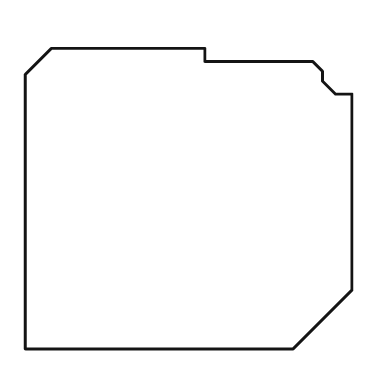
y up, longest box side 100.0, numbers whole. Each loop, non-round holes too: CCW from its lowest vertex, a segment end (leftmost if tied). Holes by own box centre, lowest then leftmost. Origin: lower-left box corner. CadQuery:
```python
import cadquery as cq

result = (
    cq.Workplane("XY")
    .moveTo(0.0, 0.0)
    .lineTo(82.0, 0.0)
    .lineTo(100.0, 18.0)
    .lineTo(100.0, 78.0)
    .lineTo(95.0, 78.0)
    .lineTo(91.0, 82.0)
    .lineTo(91.0, 85.0)
    .lineTo(88.0, 88.0)
    .lineTo(55.0, 88.0)
    .lineTo(55.0, 92.0)
    .lineTo(8.0, 92.0)
    .lineTo(0.0, 84.0)
    .close()
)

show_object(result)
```